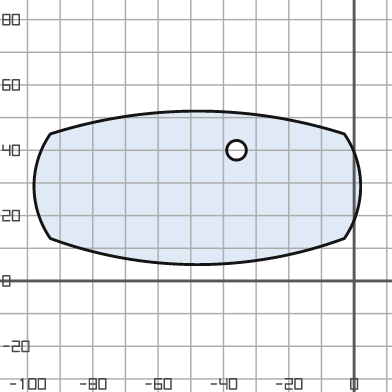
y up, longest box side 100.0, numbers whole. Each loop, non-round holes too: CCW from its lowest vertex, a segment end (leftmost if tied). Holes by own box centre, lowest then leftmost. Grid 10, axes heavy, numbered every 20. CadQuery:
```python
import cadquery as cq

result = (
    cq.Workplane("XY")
    .moveTo(-93.0, 13.0)
    .threePointArc((-48.0, 5.0), (-3.0, 13.0))
    .threePointArc((2.0, 29.0), (-3.0, 45.0))
    .threePointArc((-48.0, 52.0), (-93.0, 45.0))
    .threePointArc((-98.0, 29.0), (-93.0, 13.0))
    .close()
    .moveTo(-36.0, 40.0)
    .circle(3.0)
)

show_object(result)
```